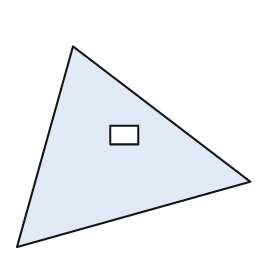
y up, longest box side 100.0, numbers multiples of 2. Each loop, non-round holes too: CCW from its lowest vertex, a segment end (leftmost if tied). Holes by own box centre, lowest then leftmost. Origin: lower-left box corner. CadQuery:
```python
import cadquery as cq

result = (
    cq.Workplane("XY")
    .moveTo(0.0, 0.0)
    .lineTo(100.0, 28.0)
    .lineTo(24.0, 86.0)
    .close()
    .moveTo(40.0, 44.0)
    .lineTo(52.0, 44.0)
    .lineTo(52.0, 52.0)
    .lineTo(40.0, 52.0)
    .close()
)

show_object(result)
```